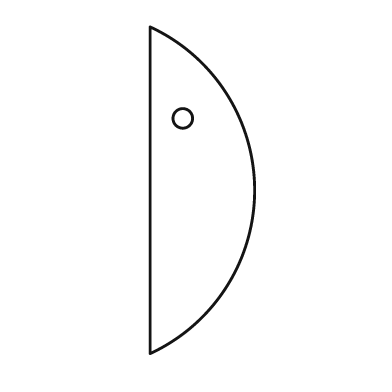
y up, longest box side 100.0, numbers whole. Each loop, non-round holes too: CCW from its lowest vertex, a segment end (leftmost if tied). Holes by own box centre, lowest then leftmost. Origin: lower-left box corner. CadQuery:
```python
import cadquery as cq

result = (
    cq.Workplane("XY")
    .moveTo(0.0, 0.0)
    .threePointArc((32.0, 50.0), (0.0, 100.0))
    .close()
    .moveTo(10.0, 72.0)
    .circle(3.0)
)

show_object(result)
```